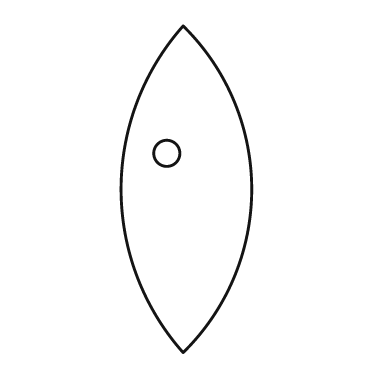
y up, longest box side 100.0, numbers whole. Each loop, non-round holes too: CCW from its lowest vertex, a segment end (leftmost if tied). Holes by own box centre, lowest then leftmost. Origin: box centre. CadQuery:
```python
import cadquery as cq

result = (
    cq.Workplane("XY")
    .moveTo(-1.0, -50.0)
    .threePointArc((20.0, 0.0), (-1.0, 50.0))
    .threePointArc((-20.0, 0.0), (-1.0, -50.0))
    .close()
    .moveTo(-6.0, 11.0)
    .circle(4.0)
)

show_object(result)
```